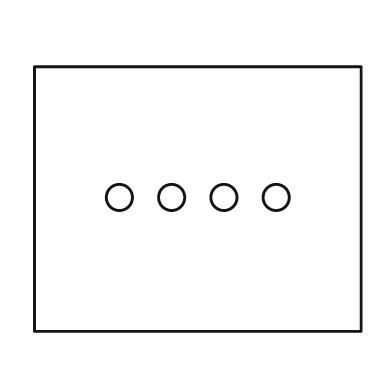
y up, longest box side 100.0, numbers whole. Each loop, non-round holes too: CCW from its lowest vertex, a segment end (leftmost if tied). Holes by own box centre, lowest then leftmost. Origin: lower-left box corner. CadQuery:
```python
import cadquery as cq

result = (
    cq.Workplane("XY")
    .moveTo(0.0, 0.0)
    .lineTo(100.0, 0.0)
    .lineTo(100.0, 81.0)
    .lineTo(0.0, 81.0)
    .close()
    .moveTo(26.0, 41.0)
    .circle(4.0)
    .moveTo(42.0, 41.0)
    .circle(4.0)
    .moveTo(58.0, 41.0)
    .circle(4.0)
    .moveTo(74.0, 41.0)
    .circle(4.0)
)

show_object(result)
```